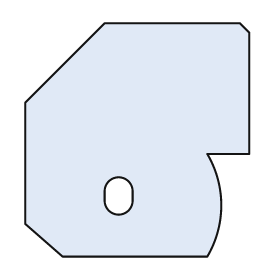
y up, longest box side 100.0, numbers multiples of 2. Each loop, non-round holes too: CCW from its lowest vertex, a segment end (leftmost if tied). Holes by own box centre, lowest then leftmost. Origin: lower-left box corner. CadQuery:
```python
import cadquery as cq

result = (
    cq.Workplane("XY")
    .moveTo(16.0, 0.0)
    .lineTo(78.0, 0.0)
    .threePointArc((84.0, 22.0), (78.0, 44.0))
    .lineTo(96.0, 44.0)
    .lineTo(96.0, 96.0)
    .lineTo(92.0, 100.0)
    .lineTo(34.0, 100.0)
    .lineTo(0.0, 66.0)
    .lineTo(0.0, 14.0)
    .close()
    .moveTo(34.0, 24.0)
    .threePointArc((40.0, 18.0), (46.0, 24.0))
    .lineTo(46.0, 28.0)
    .threePointArc((40.0, 34.0), (34.0, 28.0))
    .close()
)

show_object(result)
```